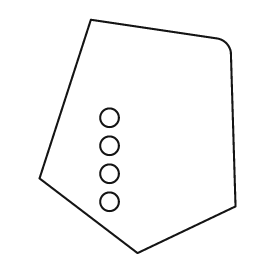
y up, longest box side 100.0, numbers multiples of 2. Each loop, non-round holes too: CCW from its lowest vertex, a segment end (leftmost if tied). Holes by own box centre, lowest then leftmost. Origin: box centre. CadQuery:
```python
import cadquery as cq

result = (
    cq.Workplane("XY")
    .moveTo(0.0, -50.0)
    .lineTo(42.0, -30.0)
    .lineTo(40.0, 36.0)
    .threePointArc((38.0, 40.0), (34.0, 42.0))
    .lineTo(-20.0, 50.0)
    .lineTo(-42.0, -18.0)
    .close()
    .moveTo(-12.0, -28.0)
    .circle(4.0)
    .moveTo(-12.0, -16.0)
    .circle(4.0)
    .moveTo(-12.0, -4.0)
    .circle(4.0)
    .moveTo(-12.0, 8.0)
    .circle(4.0)
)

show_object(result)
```